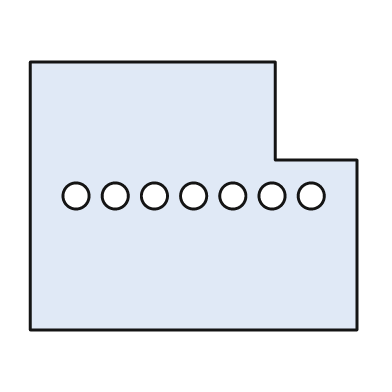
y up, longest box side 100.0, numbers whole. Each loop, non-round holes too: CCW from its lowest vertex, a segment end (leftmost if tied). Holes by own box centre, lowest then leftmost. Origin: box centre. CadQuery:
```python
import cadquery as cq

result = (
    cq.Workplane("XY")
    .moveTo(-50.0, -41.0)
    .lineTo(50.0, -41.0)
    .lineTo(50.0, 11.0)
    .lineTo(25.0, 11.0)
    .lineTo(25.0, 41.0)
    .lineTo(-50.0, 41.0)
    .close()
    .moveTo(-36.0, 0.0)
    .circle(4.0)
    .moveTo(-24.0, 0.0)
    .circle(4.0)
    .moveTo(-12.0, 0.0)
    .circle(4.0)
    .moveTo(0.0, 0.0)
    .circle(4.0)
    .moveTo(12.0, 0.0)
    .circle(4.0)
    .moveTo(24.0, 0.0)
    .circle(4.0)
    .moveTo(36.0, 0.0)
    .circle(4.0)
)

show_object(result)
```